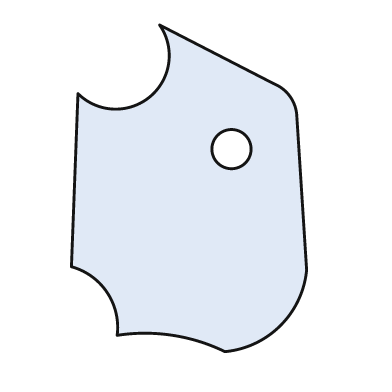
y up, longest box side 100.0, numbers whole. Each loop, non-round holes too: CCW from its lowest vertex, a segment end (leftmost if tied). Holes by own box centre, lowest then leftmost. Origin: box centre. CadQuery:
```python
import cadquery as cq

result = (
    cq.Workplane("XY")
    .moveTo(11.0, -50.0)
    .threePointArc((28.0, -42.0), (36.0, -25.0))
    .lineTo(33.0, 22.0)
    .threePointArc((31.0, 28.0), (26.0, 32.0))
    .lineTo(-9.0, 50.0)
    .threePointArc((-12.0, 28.0), (-34.0, 29.0))
    .lineTo(-36.0, -24.0)
    .threePointArc((-25.0, -32.0), (-22.0, -45.0))
    .threePointArc((-5.0, -45.0), (11.0, -50.0))
    .close()
    .moveTo(13.0, 12.0)
    .circle(6.0)
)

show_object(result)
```